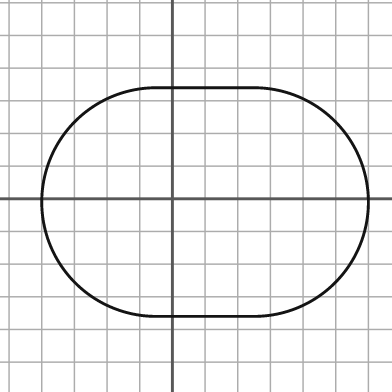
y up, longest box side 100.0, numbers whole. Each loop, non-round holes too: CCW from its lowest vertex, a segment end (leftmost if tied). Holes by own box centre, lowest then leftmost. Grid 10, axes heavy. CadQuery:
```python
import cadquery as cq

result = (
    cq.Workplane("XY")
    .moveTo(-5.0, -36.0)
    .lineTo(25.0, -36.0)
    .threePointArc((60.0, -1.0), (25.0, 34.0))
    .lineTo(-5.0, 34.0)
    .threePointArc((-40.0, -1.0), (-5.0, -36.0))
    .close()
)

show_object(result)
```